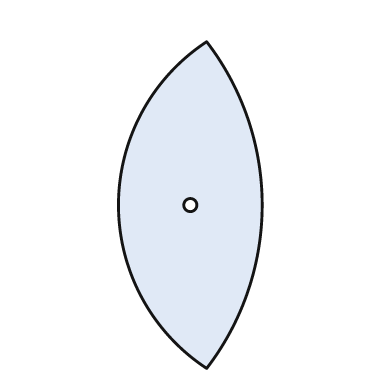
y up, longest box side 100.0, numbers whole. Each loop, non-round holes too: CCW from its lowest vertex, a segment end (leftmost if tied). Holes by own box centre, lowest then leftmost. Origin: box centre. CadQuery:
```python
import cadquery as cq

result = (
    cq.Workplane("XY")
    .moveTo(5.0, -50.0)
    .threePointArc((22.0, 0.0), (5.0, 50.0))
    .threePointArc((-22.0, 0.0), (5.0, -50.0))
    .close()
    .moveTo(0.0, 0.0)
    .circle(2.0)
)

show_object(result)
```